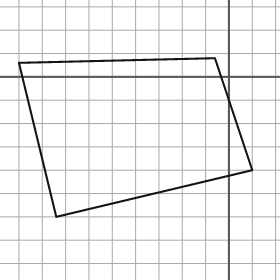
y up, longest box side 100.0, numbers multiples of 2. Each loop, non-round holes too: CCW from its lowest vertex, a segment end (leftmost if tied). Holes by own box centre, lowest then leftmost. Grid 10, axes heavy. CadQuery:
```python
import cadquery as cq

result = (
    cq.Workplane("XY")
    .moveTo(-74.0, -60.0)
    .lineTo(10.0, -40.0)
    .lineTo(-6.0, 8.0)
    .lineTo(-90.0, 6.0)
    .close()
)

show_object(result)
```